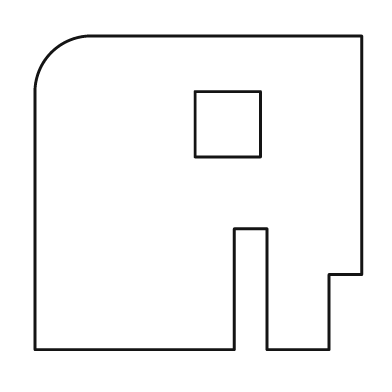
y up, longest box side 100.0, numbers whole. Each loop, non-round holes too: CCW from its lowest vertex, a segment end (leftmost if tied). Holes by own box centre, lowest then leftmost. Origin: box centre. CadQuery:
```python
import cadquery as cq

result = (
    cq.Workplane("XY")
    .moveTo(-50.0, -48.0)
    .lineTo(11.0, -48.0)
    .lineTo(11.0, -11.0)
    .lineTo(21.0, -11.0)
    .lineTo(21.0, -48.0)
    .lineTo(40.0, -48.0)
    .lineTo(40.0, -25.0)
    .lineTo(50.0, -25.0)
    .lineTo(50.0, 48.0)
    .lineTo(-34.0, 48.0)
    .threePointArc((-45.0, 43.0), (-50.0, 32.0))
    .close()
    .moveTo(-1.0, 11.0)
    .lineTo(19.0, 11.0)
    .lineTo(19.0, 31.0)
    .lineTo(-1.0, 31.0)
    .close()
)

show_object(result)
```